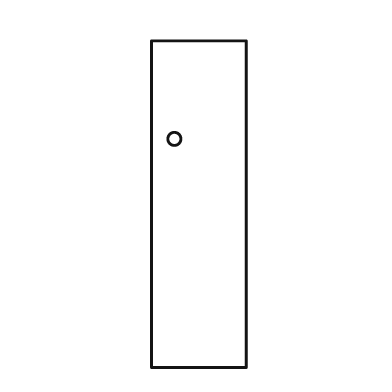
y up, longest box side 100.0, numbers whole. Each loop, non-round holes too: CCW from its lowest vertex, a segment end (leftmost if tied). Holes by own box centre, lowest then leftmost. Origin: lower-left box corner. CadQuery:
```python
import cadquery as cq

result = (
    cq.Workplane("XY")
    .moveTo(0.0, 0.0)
    .lineTo(29.0, 0.0)
    .lineTo(29.0, 100.0)
    .lineTo(0.0, 100.0)
    .close()
    .moveTo(7.0, 70.0)
    .circle(2.0)
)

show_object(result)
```